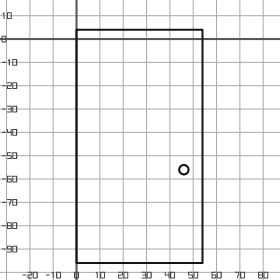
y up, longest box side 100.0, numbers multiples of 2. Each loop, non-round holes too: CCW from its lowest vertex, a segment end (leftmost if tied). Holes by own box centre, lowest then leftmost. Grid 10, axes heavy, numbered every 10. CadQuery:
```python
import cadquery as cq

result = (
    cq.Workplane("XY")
    .moveTo(0.0, -96.0)
    .lineTo(54.0, -96.0)
    .lineTo(54.0, 4.0)
    .lineTo(0.0, 4.0)
    .close()
    .moveTo(46.0, -56.0)
    .circle(2.0)
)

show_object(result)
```